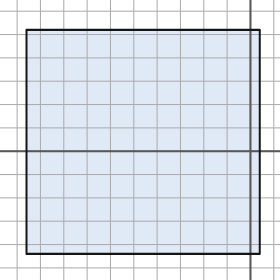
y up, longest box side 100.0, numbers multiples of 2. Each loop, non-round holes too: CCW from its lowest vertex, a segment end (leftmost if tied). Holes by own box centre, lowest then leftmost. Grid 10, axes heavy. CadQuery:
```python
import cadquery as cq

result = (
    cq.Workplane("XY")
    .moveTo(-96.0, -44.0)
    .lineTo(4.0, -44.0)
    .lineTo(4.0, 52.0)
    .lineTo(-96.0, 52.0)
    .close()
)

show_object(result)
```